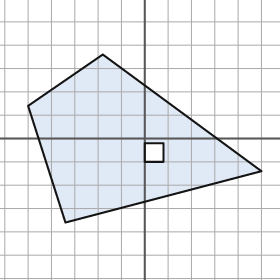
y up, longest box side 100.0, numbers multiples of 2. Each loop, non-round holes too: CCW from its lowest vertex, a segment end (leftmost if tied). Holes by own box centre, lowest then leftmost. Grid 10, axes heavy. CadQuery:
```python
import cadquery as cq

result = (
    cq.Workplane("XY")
    .moveTo(-34.0, -36.0)
    .lineTo(50.0, -14.0)
    .lineTo(-18.0, 36.0)
    .lineTo(-50.0, 14.0)
    .close()
    .moveTo(0.0, -10.0)
    .lineTo(8.0, -10.0)
    .lineTo(8.0, -2.0)
    .lineTo(0.0, -2.0)
    .close()
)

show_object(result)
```